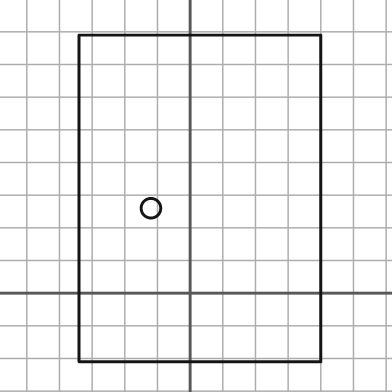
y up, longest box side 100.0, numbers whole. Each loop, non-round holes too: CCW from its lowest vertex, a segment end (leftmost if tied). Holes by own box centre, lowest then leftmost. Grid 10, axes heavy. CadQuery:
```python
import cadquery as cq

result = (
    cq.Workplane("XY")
    .moveTo(-34.0, -21.0)
    .lineTo(40.0, -21.0)
    .lineTo(40.0, 79.0)
    .lineTo(-34.0, 79.0)
    .close()
    .moveTo(-12.0, 26.0)
    .circle(3.0)
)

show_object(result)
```